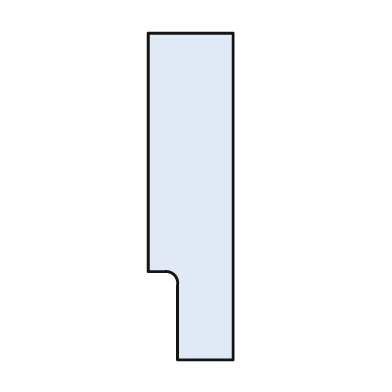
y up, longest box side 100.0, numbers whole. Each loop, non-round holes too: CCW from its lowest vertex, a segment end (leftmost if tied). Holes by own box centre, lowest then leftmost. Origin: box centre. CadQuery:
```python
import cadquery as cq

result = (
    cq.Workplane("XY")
    .moveTo(-4.0, -50.0)
    .lineTo(13.0, -50.0)
    .lineTo(13.0, 50.0)
    .lineTo(-13.0, 50.0)
    .lineTo(-13.0, -23.0)
    .lineTo(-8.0, -23.0)
    .threePointArc((-5.0, -24.0), (-4.0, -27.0))
    .close()
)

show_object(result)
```